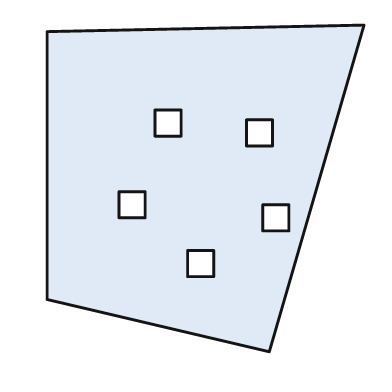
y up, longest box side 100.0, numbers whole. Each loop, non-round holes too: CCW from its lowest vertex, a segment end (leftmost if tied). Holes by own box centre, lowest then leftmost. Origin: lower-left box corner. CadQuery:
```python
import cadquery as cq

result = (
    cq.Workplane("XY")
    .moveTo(68.0, 0.0)
    .lineTo(97.0, 100.0)
    .lineTo(0.0, 98.0)
    .lineTo(0.0, 16.0)
    .close()
    .moveTo(43.0, 23.0)
    .lineTo(51.0, 23.0)
    .lineTo(51.0, 31.0)
    .lineTo(43.0, 31.0)
    .close()
    .moveTo(66.0, 37.0)
    .lineTo(74.0, 37.0)
    .lineTo(74.0, 45.0)
    .lineTo(66.0, 45.0)
    .close()
    .moveTo(22.0, 41.0)
    .lineTo(30.0, 41.0)
    .lineTo(30.0, 49.0)
    .lineTo(22.0, 49.0)
    .close()
    .moveTo(61.0, 63.0)
    .lineTo(69.0, 63.0)
    .lineTo(69.0, 71.0)
    .lineTo(61.0, 71.0)
    .close()
    .moveTo(33.0, 66.0)
    .lineTo(41.0, 66.0)
    .lineTo(41.0, 74.0)
    .lineTo(33.0, 74.0)
    .close()
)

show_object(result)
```